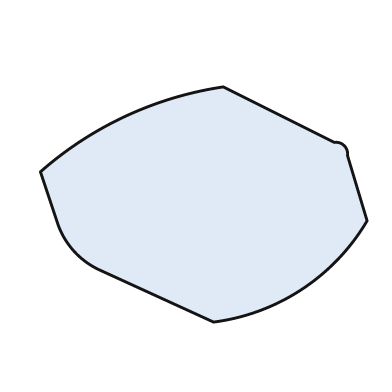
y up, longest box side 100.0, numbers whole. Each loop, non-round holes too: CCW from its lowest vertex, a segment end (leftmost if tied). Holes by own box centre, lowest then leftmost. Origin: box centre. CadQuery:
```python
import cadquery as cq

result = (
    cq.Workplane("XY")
    .moveTo(3.0, -36.0)
    .threePointArc((30.0, -26.0), (50.0, -5.0))
    .lineTo(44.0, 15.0)
    .threePointArc((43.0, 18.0), (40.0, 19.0))
    .lineTo(6.0, 36.0)
    .threePointArc((-24.0, 27.0), (-50.0, 10.0))
    .lineTo(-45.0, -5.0)
    .threePointArc((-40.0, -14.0), (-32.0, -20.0))
    .close()
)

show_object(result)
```